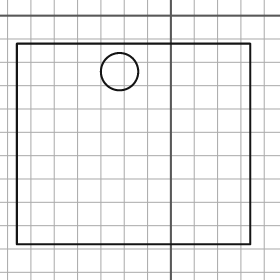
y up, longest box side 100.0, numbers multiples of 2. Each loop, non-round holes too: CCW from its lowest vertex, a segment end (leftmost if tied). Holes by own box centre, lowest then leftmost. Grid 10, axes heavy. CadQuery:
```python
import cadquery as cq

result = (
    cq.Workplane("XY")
    .moveTo(-66.0, -98.0)
    .lineTo(34.0, -98.0)
    .lineTo(34.0, -12.0)
    .lineTo(-66.0, -12.0)
    .close()
    .moveTo(-22.0, -24.0)
    .circle(8.0)
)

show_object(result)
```